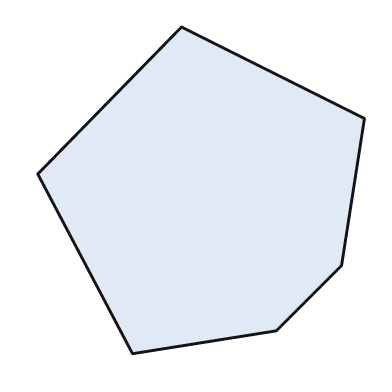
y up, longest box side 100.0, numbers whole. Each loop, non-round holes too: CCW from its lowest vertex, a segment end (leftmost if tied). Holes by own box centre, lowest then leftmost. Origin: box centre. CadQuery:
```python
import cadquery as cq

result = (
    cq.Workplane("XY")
    .moveTo(-21.0, -50.0)
    .lineTo(23.0, -43.0)
    .lineTo(43.0, -23.0)
    .lineTo(50.0, 22.0)
    .lineTo(-6.0, 50.0)
    .lineTo(-50.0, 5.0)
    .close()
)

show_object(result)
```